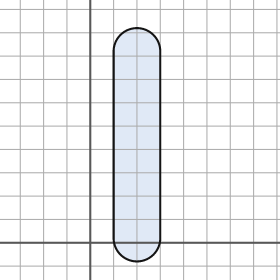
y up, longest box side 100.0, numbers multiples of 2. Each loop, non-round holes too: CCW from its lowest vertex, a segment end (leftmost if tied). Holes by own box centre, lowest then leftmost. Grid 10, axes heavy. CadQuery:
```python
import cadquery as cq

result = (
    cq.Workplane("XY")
    .moveTo(10.0, 2.0)
    .threePointArc((20.0, -8.0), (30.0, 2.0))
    .lineTo(30.0, 82.0)
    .threePointArc((20.0, 92.0), (10.0, 82.0))
    .close()
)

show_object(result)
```